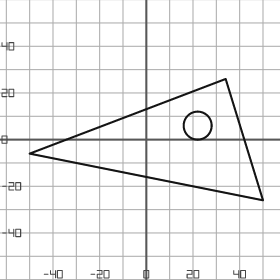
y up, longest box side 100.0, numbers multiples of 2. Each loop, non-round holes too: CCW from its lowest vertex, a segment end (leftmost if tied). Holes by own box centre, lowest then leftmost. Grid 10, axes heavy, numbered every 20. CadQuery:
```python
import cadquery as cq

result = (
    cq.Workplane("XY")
    .moveTo(50.0, -26.0)
    .lineTo(34.0, 26.0)
    .lineTo(-50.0, -6.0)
    .close()
    .moveTo(22.0, 6.0)
    .circle(6.0)
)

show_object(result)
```